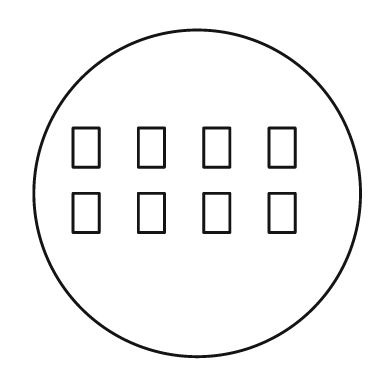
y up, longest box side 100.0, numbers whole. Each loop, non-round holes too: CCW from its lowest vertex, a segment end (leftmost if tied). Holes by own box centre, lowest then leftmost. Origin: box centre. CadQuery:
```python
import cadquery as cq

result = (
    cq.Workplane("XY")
    .moveTo(0.0, 0.0)
    .circle(50.0)
    .moveTo(-38.0, -12.0)
    .lineTo(-30.0, -12.0)
    .lineTo(-30.0, 0.0)
    .lineTo(-38.0, 0.0)
    .close()
    .moveTo(-18.0, -12.0)
    .lineTo(-10.0, -12.0)
    .lineTo(-10.0, 0.0)
    .lineTo(-18.0, 0.0)
    .close()
    .moveTo(2.0, -12.0)
    .lineTo(10.0, -12.0)
    .lineTo(10.0, 0.0)
    .lineTo(2.0, 0.0)
    .close()
    .moveTo(22.0, -12.0)
    .lineTo(30.0, -12.0)
    .lineTo(30.0, 0.0)
    .lineTo(22.0, 0.0)
    .close()
    .moveTo(-38.0, 8.0)
    .lineTo(-30.0, 8.0)
    .lineTo(-30.0, 20.0)
    .lineTo(-38.0, 20.0)
    .close()
    .moveTo(-18.0, 8.0)
    .lineTo(-10.0, 8.0)
    .lineTo(-10.0, 20.0)
    .lineTo(-18.0, 20.0)
    .close()
    .moveTo(2.0, 8.0)
    .lineTo(10.0, 8.0)
    .lineTo(10.0, 20.0)
    .lineTo(2.0, 20.0)
    .close()
    .moveTo(22.0, 8.0)
    .lineTo(30.0, 8.0)
    .lineTo(30.0, 20.0)
    .lineTo(22.0, 20.0)
    .close()
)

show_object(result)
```